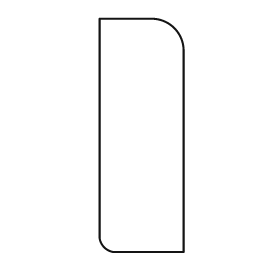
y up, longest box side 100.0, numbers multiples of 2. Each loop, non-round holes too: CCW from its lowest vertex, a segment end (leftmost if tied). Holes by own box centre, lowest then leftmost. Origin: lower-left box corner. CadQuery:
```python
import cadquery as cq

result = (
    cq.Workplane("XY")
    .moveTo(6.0, 0.0)
    .lineTo(36.0, 0.0)
    .lineTo(36.0, 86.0)
    .threePointArc((32.0, 96.0), (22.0, 100.0))
    .lineTo(0.0, 100.0)
    .lineTo(0.0, 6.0)
    .threePointArc((2.0, 2.0), (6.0, 0.0))
    .close()
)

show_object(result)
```